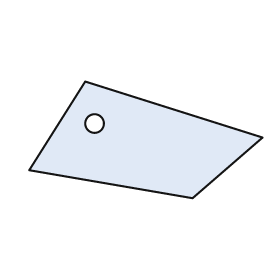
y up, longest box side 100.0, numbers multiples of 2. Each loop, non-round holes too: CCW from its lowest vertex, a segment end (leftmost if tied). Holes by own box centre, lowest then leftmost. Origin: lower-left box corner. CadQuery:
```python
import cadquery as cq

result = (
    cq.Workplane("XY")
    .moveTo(70.0, 0.0)
    .lineTo(100.0, 26.0)
    .lineTo(24.0, 50.0)
    .lineTo(0.0, 12.0)
    .close()
    .moveTo(28.0, 32.0)
    .circle(4.0)
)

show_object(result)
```